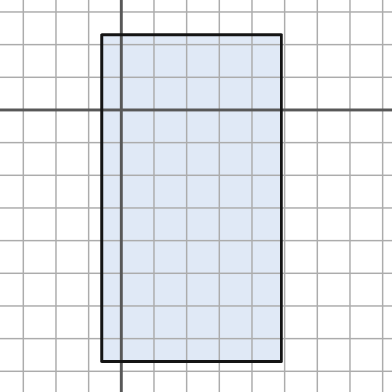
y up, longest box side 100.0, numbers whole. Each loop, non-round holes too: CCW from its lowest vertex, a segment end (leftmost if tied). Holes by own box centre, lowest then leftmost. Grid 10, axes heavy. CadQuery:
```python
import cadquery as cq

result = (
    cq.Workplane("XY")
    .moveTo(-6.0, -77.0)
    .lineTo(49.0, -77.0)
    .lineTo(49.0, 23.0)
    .lineTo(-6.0, 23.0)
    .close()
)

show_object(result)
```